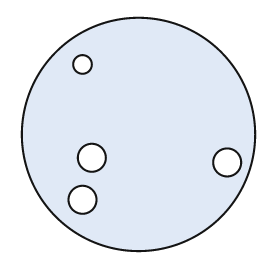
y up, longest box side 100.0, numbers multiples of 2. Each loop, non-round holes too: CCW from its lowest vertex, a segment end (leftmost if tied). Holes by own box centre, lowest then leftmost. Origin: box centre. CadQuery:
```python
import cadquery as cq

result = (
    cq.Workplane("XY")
    .moveTo(0.0, 0.0)
    .circle(50.0)
    .moveTo(-24.0, -28.0)
    .circle(6.0)
    .moveTo(38.0, -12.0)
    .circle(6.0)
    .moveTo(-20.0, -10.0)
    .circle(6.0)
    .moveTo(-24.0, 30.0)
    .circle(4.0)
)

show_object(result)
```